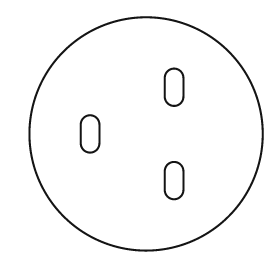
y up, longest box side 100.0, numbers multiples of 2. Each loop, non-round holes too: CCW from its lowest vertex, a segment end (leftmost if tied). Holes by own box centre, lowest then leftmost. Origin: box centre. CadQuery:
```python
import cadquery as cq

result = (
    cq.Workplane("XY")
    .moveTo(0.0, 0.0)
    .circle(50.0)
    .moveTo(8.0, -24.0)
    .threePointArc((12.0, -28.0), (16.0, -24.0))
    .lineTo(16.0, -16.0)
    .threePointArc((12.0, -12.0), (8.0, -16.0))
    .close()
    .moveTo(-28.0, -4.0)
    .threePointArc((-24.0, -8.0), (-20.0, -4.0))
    .lineTo(-20.0, 4.0)
    .threePointArc((-24.0, 8.0), (-28.0, 4.0))
    .close()
    .moveTo(8.0, 16.0)
    .threePointArc((12.0, 12.0), (16.0, 16.0))
    .lineTo(16.0, 24.0)
    .threePointArc((12.0, 28.0), (8.0, 24.0))
    .close()
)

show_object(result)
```